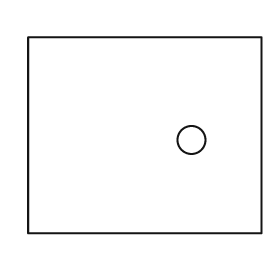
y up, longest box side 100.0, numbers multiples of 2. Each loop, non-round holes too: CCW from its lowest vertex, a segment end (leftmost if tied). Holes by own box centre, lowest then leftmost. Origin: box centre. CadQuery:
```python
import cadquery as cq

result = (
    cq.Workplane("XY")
    .moveTo(-50.0, -42.0)
    .lineTo(50.0, -42.0)
    .lineTo(50.0, 42.0)
    .lineTo(-50.0, 42.0)
    .close()
    .moveTo(20.0, -2.0)
    .circle(6.0)
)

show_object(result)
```